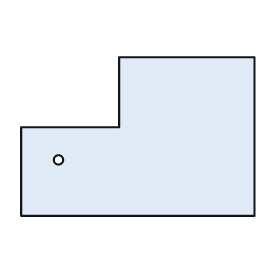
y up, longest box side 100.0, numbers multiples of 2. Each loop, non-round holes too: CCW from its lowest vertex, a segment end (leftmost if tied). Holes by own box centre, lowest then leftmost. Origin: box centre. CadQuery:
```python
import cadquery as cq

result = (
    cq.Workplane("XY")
    .moveTo(-50.0, -34.0)
    .lineTo(50.0, -34.0)
    .lineTo(50.0, 34.0)
    .lineTo(-8.0, 34.0)
    .lineTo(-8.0, 4.0)
    .lineTo(-50.0, 4.0)
    .close()
    .moveTo(-34.0, -10.0)
    .circle(2.0)
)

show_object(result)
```